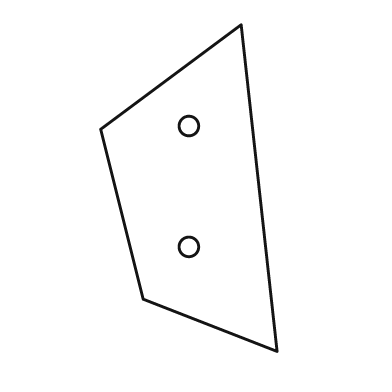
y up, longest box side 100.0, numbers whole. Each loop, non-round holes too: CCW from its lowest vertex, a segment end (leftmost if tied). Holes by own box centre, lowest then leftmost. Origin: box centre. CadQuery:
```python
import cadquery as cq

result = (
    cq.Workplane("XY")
    .moveTo(27.0, -50.0)
    .lineTo(16.0, 50.0)
    .lineTo(-27.0, 18.0)
    .lineTo(-14.0, -34.0)
    .close()
    .moveTo(0.0, -18.0)
    .circle(3.0)
    .moveTo(0.0, 19.0)
    .circle(3.0)
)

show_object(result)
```